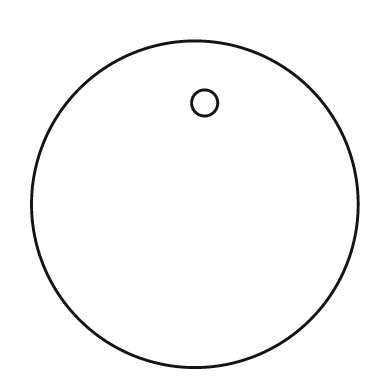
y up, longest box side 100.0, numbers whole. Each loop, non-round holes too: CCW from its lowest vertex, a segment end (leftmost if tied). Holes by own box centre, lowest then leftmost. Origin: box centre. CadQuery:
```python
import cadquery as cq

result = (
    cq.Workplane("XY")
    .moveTo(0.0, 0.0)
    .circle(50.0)
    .moveTo(3.0, 31.0)
    .circle(4.0)
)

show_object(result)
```